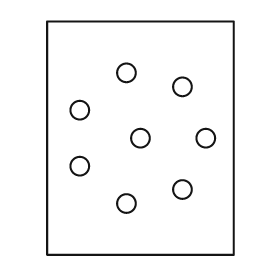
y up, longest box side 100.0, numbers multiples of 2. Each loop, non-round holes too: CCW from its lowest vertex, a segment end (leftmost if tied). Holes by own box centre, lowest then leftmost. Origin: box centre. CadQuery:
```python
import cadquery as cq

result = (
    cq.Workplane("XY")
    .moveTo(-40.0, -50.0)
    .lineTo(40.0, -50.0)
    .lineTo(40.0, 50.0)
    .lineTo(-40.0, 50.0)
    .close()
    .moveTo(-6.0, -28.0)
    .circle(4.0)
    .moveTo(18.0, -22.0)
    .circle(4.0)
    .moveTo(-26.0, -12.0)
    .circle(4.0)
    .moveTo(0.0, 0.0)
    .circle(4.0)
    .moveTo(28.0, 0.0)
    .circle(4.0)
    .moveTo(-26.0, 12.0)
    .circle(4.0)
    .moveTo(18.0, 22.0)
    .circle(4.0)
    .moveTo(-6.0, 28.0)
    .circle(4.0)
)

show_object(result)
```